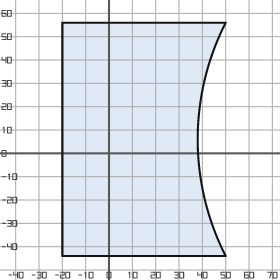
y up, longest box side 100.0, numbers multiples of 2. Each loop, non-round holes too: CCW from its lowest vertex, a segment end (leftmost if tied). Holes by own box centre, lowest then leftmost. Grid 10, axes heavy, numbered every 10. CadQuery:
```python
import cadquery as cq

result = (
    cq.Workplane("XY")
    .moveTo(-20.0, -44.0)
    .lineTo(50.0, -44.0)
    .threePointArc((38.0, 6.0), (50.0, 56.0))
    .lineTo(-20.0, 56.0)
    .close()
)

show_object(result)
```